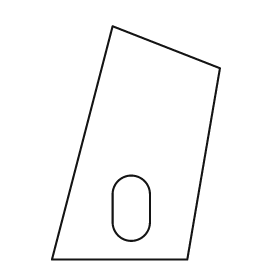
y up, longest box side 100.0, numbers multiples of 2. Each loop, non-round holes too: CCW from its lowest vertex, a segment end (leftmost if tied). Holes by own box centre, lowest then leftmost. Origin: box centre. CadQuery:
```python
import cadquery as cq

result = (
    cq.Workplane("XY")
    .moveTo(-36.0, -50.0)
    .lineTo(22.0, -50.0)
    .lineTo(36.0, 32.0)
    .lineTo(-10.0, 50.0)
    .close()
    .moveTo(-10.0, -34.0)
    .threePointArc((-2.0, -42.0), (6.0, -34.0))
    .lineTo(6.0, -22.0)
    .threePointArc((-2.0, -14.0), (-10.0, -22.0))
    .close()
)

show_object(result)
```